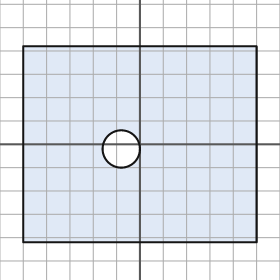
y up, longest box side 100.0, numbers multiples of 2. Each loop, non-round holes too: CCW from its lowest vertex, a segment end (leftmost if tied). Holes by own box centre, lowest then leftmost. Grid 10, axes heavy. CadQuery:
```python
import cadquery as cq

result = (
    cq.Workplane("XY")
    .moveTo(-50.0, -42.0)
    .lineTo(50.0, -42.0)
    .lineTo(50.0, 42.0)
    .lineTo(-50.0, 42.0)
    .close()
    .moveTo(-8.0, -2.0)
    .circle(8.0)
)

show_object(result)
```